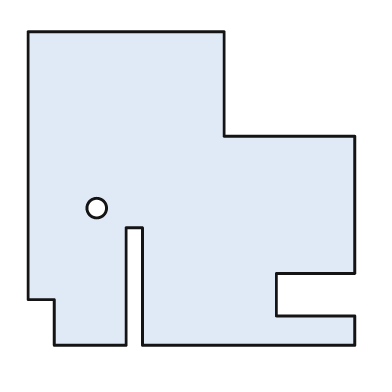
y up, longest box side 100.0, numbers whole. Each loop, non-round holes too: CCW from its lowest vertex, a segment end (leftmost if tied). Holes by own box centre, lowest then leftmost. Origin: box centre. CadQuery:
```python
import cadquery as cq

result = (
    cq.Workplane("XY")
    .moveTo(-42.0, -48.0)
    .lineTo(-20.0, -48.0)
    .lineTo(-20.0, -12.0)
    .lineTo(-15.0, -12.0)
    .lineTo(-15.0, -48.0)
    .lineTo(50.0, -48.0)
    .lineTo(50.0, -39.0)
    .lineTo(26.0, -39.0)
    .lineTo(26.0, -26.0)
    .lineTo(50.0, -26.0)
    .lineTo(50.0, 16.0)
    .lineTo(10.0, 16.0)
    .lineTo(10.0, 48.0)
    .lineTo(-50.0, 48.0)
    .lineTo(-50.0, -34.0)
    .lineTo(-42.0, -34.0)
    .close()
    .moveTo(-29.0, -6.0)
    .circle(3.0)
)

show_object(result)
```